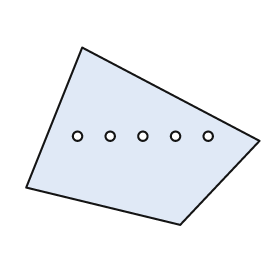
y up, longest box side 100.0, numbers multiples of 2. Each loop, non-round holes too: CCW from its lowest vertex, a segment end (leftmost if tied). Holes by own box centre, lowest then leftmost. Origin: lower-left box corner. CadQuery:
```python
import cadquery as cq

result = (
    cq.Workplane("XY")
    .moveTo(66.0, 0.0)
    .lineTo(100.0, 36.0)
    .lineTo(24.0, 76.0)
    .lineTo(0.0, 16.0)
    .close()
    .moveTo(22.0, 38.0)
    .circle(2.0)
    .moveTo(36.0, 38.0)
    .circle(2.0)
    .moveTo(50.0, 38.0)
    .circle(2.0)
    .moveTo(64.0, 38.0)
    .circle(2.0)
    .moveTo(78.0, 38.0)
    .circle(2.0)
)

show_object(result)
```